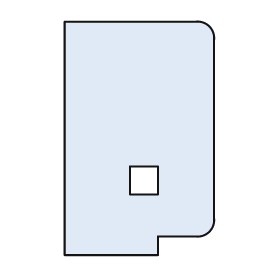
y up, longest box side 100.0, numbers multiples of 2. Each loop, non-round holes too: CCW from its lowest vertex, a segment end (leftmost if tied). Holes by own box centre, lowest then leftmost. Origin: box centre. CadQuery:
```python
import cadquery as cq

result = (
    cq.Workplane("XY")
    .moveTo(-32.0, -50.0)
    .lineTo(8.0, -50.0)
    .lineTo(8.0, -42.0)
    .lineTo(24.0, -42.0)
    .threePointArc((30.0, -40.0), (32.0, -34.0))
    .lineTo(32.0, 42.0)
    .threePointArc((30.0, 48.0), (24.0, 50.0))
    .lineTo(-32.0, 50.0)
    .close()
    .moveTo(-4.0, -24.0)
    .lineTo(8.0, -24.0)
    .lineTo(8.0, -12.0)
    .lineTo(-4.0, -12.0)
    .close()
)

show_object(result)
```